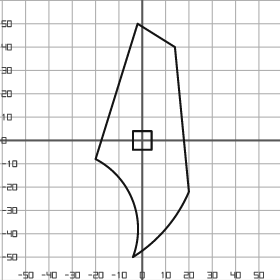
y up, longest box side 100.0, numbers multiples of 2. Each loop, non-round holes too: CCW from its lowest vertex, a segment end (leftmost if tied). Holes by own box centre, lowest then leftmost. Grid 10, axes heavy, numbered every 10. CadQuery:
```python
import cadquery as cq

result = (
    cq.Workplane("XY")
    .moveTo(-4.0, -50.0)
    .threePointArc((10.0, -38.0), (20.0, -22.0))
    .lineTo(14.0, 40.0)
    .lineTo(-2.0, 50.0)
    .lineTo(-20.0, -8.0)
    .threePointArc((-4.0, -26.0), (-4.0, -50.0))
    .close()
    .moveTo(-4.0, -4.0)
    .lineTo(4.0, -4.0)
    .lineTo(4.0, 4.0)
    .lineTo(-4.0, 4.0)
    .close()
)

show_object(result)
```